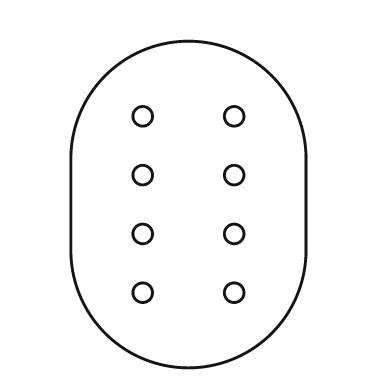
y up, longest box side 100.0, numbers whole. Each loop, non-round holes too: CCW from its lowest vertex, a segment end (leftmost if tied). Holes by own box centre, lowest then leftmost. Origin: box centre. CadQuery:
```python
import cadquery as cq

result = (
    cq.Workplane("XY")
    .moveTo(-36.0, -14.0)
    .threePointArc((0.0, -50.0), (36.0, -14.0))
    .lineTo(36.0, 14.0)
    .threePointArc((0.0, 50.0), (-36.0, 14.0))
    .close()
    .moveTo(-14.0, -27.0)
    .circle(3.0)
    .moveTo(14.0, -27.0)
    .circle(3.0)
    .moveTo(-14.0, -9.0)
    .circle(3.0)
    .moveTo(14.0, -9.0)
    .circle(3.0)
    .moveTo(-14.0, 9.0)
    .circle(3.0)
    .moveTo(14.0, 9.0)
    .circle(3.0)
    .moveTo(-14.0, 27.0)
    .circle(3.0)
    .moveTo(14.0, 27.0)
    .circle(3.0)
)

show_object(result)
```